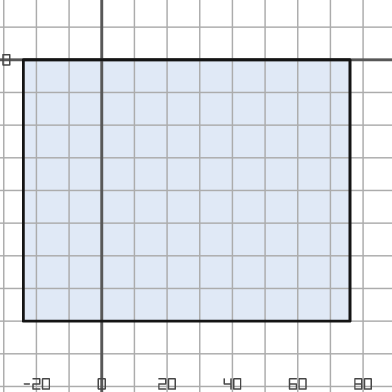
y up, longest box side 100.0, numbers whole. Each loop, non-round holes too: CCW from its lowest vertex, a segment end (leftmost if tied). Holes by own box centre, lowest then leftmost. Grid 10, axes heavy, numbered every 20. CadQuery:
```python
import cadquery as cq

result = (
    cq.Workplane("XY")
    .moveTo(-24.0, -80.0)
    .lineTo(76.0, -80.0)
    .lineTo(76.0, 0.0)
    .lineTo(-24.0, 0.0)
    .close()
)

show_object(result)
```